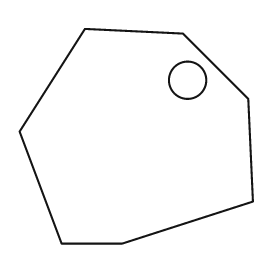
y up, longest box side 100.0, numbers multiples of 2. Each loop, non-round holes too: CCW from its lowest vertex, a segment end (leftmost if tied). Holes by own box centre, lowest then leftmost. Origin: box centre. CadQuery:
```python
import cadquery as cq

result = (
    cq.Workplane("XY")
    .moveTo(-32.0, -46.0)
    .lineTo(-6.0, -46.0)
    .lineTo(50.0, -28.0)
    .lineTo(48.0, 16.0)
    .lineTo(20.0, 44.0)
    .lineTo(-22.0, 46.0)
    .lineTo(-50.0, 2.0)
    .close()
    .moveTo(22.0, 24.0)
    .circle(8.0)
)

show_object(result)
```